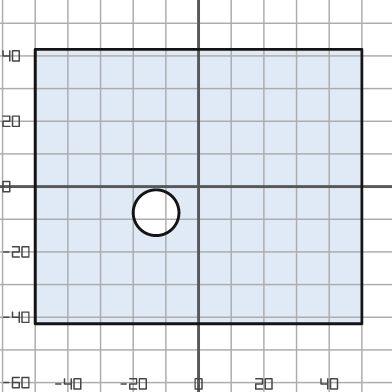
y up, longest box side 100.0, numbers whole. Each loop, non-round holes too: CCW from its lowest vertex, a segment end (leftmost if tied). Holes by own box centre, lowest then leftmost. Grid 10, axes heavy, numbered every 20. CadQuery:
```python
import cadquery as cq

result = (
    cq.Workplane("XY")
    .moveTo(-50.0, -42.0)
    .lineTo(50.0, -42.0)
    .lineTo(50.0, 42.0)
    .lineTo(-50.0, 42.0)
    .close()
    .moveTo(-13.0, -8.0)
    .circle(7.0)
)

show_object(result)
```